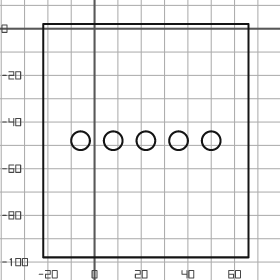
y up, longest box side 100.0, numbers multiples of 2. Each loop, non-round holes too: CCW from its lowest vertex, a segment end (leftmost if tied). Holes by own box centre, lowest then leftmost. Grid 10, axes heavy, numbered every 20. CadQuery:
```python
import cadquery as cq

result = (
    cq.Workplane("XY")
    .moveTo(-22.0, -98.0)
    .lineTo(66.0, -98.0)
    .lineTo(66.0, 2.0)
    .lineTo(-22.0, 2.0)
    .close()
    .moveTo(-6.0, -48.0)
    .circle(4.0)
    .moveTo(8.0, -48.0)
    .circle(4.0)
    .moveTo(22.0, -48.0)
    .circle(4.0)
    .moveTo(36.0, -48.0)
    .circle(4.0)
    .moveTo(50.0, -48.0)
    .circle(4.0)
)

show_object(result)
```